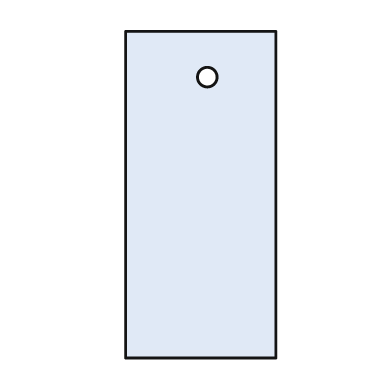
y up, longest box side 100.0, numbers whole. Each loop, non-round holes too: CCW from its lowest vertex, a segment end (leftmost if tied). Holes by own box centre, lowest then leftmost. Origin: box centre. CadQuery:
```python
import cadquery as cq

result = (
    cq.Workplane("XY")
    .moveTo(-23.0, -50.0)
    .lineTo(23.0, -50.0)
    .lineTo(23.0, 50.0)
    .lineTo(-23.0, 50.0)
    .close()
    .moveTo(2.0, 36.0)
    .circle(3.0)
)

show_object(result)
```